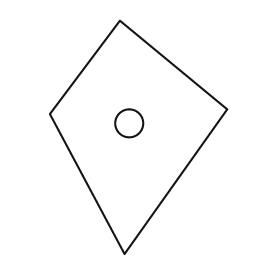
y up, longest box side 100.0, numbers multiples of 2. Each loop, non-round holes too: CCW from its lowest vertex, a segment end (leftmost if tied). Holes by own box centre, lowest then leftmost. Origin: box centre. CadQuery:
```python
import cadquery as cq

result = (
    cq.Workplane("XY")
    .moveTo(-6.0, -50.0)
    .lineTo(38.0, 12.0)
    .lineTo(-8.0, 50.0)
    .lineTo(-38.0, 10.0)
    .close()
    .moveTo(-4.0, 6.0)
    .circle(6.0)
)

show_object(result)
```